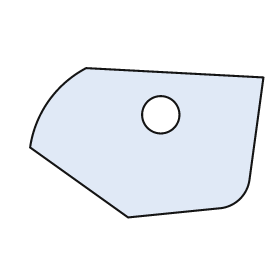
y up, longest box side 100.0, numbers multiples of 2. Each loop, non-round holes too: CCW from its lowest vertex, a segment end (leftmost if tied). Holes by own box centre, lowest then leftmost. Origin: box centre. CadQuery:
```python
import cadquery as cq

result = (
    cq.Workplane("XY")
    .moveTo(-8.0, -32.0)
    .lineTo(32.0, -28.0)
    .threePointArc((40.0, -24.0), (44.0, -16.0))
    .lineTo(50.0, 28.0)
    .lineTo(-26.0, 32.0)
    .threePointArc((-42.0, 18.0), (-50.0, -2.0))
    .close()
    .moveTo(6.0, 12.0)
    .circle(8.0)
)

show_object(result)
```